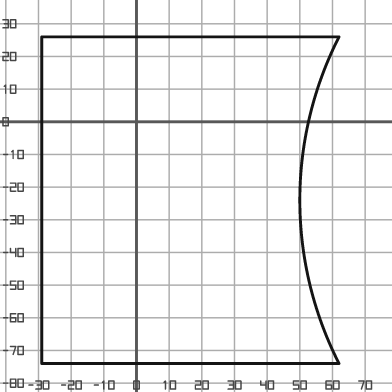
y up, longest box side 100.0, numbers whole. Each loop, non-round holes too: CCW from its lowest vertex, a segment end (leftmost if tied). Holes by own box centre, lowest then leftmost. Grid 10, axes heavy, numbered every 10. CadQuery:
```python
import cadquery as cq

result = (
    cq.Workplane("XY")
    .moveTo(-29.0, -74.0)
    .lineTo(62.0, -74.0)
    .threePointArc((50.0, -24.0), (62.0, 26.0))
    .lineTo(-29.0, 26.0)
    .close()
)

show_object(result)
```